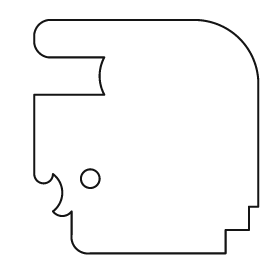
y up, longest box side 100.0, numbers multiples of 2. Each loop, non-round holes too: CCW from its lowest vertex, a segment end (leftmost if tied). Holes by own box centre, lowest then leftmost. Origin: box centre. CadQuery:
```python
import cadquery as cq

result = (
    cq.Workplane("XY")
    .moveTo(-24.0, -50.0)
    .lineTo(34.0, -50.0)
    .lineTo(34.0, -40.0)
    .lineTo(44.0, -40.0)
    .lineTo(44.0, -30.0)
    .lineTo(48.0, -30.0)
    .lineTo(48.0, 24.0)
    .threePointArc((40.0, 42.0), (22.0, 50.0))
    .lineTo(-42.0, 50.0)
    .threePointArc((-46.0, 48.0), (-48.0, 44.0))
    .lineTo(-48.0, 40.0)
    .threePointArc((-46.0, 36.0), (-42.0, 34.0))
    .lineTo(-18.0, 34.0)
    .threePointArc((-20.0, 26.0), (-18.0, 18.0))
    .lineTo(-48.0, 18.0)
    .lineTo(-48.0, -16.0)
    .threePointArc((-44.0, -20.0), (-40.0, -16.0))
    .threePointArc((-36.0, -24.0), (-40.0, -32.0))
    .threePointArc((-36.0, -34.0), (-32.0, -32.0))
    .lineTo(-32.0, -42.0)
    .threePointArc((-30.0, -48.0), (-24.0, -50.0))
    .close()
    .moveTo(-24.0, -18.0)
    .circle(4.0)
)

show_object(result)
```